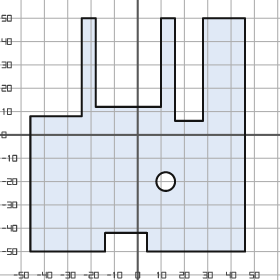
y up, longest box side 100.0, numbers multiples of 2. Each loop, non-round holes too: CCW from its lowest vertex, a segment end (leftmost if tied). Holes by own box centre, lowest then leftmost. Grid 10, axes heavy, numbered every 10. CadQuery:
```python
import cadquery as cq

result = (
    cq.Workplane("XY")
    .moveTo(-46.0, -50.0)
    .lineTo(-14.0, -50.0)
    .lineTo(-14.0, -42.0)
    .lineTo(4.0, -42.0)
    .lineTo(4.0, -50.0)
    .lineTo(46.0, -50.0)
    .lineTo(46.0, 50.0)
    .lineTo(28.0, 50.0)
    .lineTo(28.0, 6.0)
    .lineTo(16.0, 6.0)
    .lineTo(16.0, 50.0)
    .lineTo(10.0, 50.0)
    .lineTo(10.0, 12.0)
    .lineTo(-18.0, 12.0)
    .lineTo(-18.0, 50.0)
    .lineTo(-24.0, 50.0)
    .lineTo(-24.0, 8.0)
    .lineTo(-46.0, 8.0)
    .close()
    .moveTo(12.0, -20.0)
    .circle(4.0)
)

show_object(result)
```